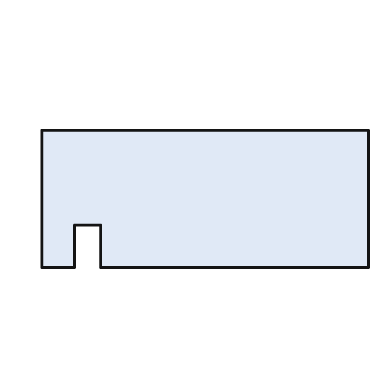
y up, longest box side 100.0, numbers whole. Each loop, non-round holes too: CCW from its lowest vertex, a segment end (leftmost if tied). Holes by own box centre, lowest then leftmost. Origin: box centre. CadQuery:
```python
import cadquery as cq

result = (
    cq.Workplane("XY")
    .moveTo(-50.0, -21.0)
    .lineTo(-40.0, -21.0)
    .lineTo(-40.0, -8.0)
    .lineTo(-32.0, -8.0)
    .lineTo(-32.0, -21.0)
    .lineTo(50.0, -21.0)
    .lineTo(50.0, 21.0)
    .lineTo(-50.0, 21.0)
    .close()
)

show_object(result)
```